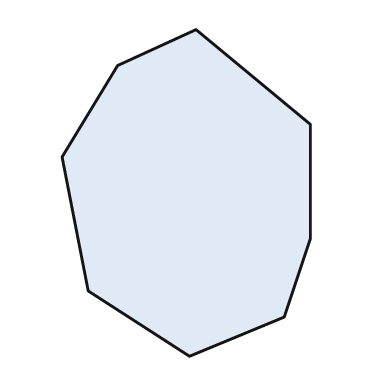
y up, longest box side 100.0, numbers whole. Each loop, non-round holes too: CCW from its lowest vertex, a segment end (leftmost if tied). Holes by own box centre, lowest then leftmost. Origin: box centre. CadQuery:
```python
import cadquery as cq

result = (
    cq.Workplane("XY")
    .moveTo(1.0, -50.0)
    .lineTo(30.0, -38.0)
    .lineTo(38.0, -14.0)
    .lineTo(38.0, 21.0)
    .lineTo(3.0, 50.0)
    .lineTo(-21.0, 39.0)
    .lineTo(-38.0, 11.0)
    .lineTo(-30.0, -30.0)
    .close()
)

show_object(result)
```